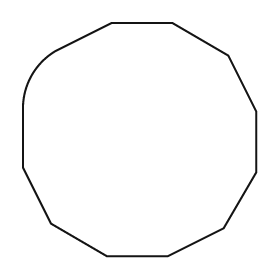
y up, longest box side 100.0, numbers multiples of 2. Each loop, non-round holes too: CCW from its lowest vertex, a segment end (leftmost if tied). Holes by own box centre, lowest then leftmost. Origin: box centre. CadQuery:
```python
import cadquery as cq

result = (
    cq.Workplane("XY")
    .moveTo(-14.0, -50.0)
    .lineTo(12.0, -50.0)
    .lineTo(36.0, -38.0)
    .lineTo(50.0, -14.0)
    .lineTo(50.0, 12.0)
    .lineTo(38.0, 36.0)
    .lineTo(14.0, 50.0)
    .lineTo(-12.0, 50.0)
    .lineTo(-36.0, 38.0)
    .threePointArc((-46.0, 28.0), (-50.0, 14.0))
    .lineTo(-50.0, -12.0)
    .lineTo(-38.0, -36.0)
    .close()
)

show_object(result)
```